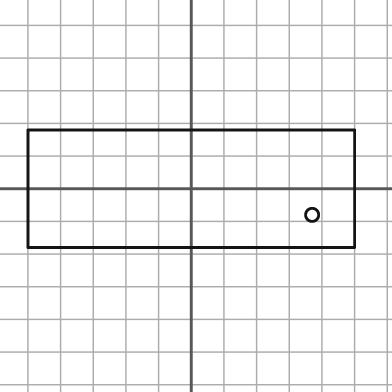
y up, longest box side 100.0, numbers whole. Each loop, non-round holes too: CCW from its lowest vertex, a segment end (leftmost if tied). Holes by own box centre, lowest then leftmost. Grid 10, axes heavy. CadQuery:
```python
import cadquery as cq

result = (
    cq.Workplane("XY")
    .moveTo(-50.0, -18.0)
    .lineTo(50.0, -18.0)
    .lineTo(50.0, 18.0)
    .lineTo(-50.0, 18.0)
    .close()
    .moveTo(37.0, -8.0)
    .circle(2.0)
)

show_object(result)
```